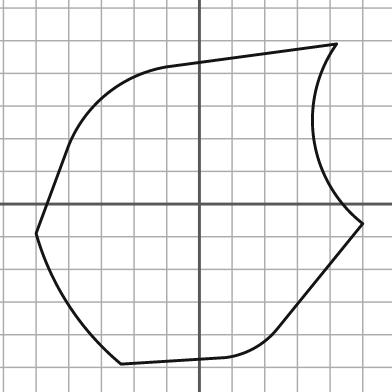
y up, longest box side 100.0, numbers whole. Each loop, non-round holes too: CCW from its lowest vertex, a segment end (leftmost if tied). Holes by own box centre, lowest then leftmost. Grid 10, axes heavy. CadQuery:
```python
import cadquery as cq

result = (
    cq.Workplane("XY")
    .moveTo(-24.0, -49.0)
    .lineTo(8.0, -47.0)
    .threePointArc((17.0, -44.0), (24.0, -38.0))
    .lineTo(50.0, -6.0)
    .threePointArc((35.0, 20.0), (42.0, 49.0))
    .lineTo(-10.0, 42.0)
    .threePointArc((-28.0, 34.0), (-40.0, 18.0))
    .lineTo(-50.0, -9.0)
    .threePointArc((-40.0, -31.0), (-24.0, -49.0))
    .close()
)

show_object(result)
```